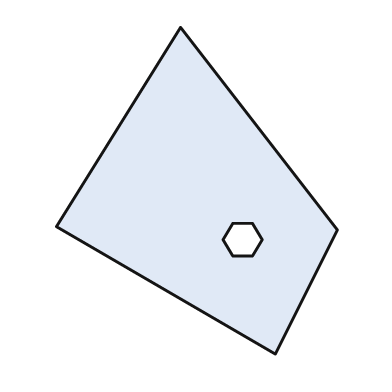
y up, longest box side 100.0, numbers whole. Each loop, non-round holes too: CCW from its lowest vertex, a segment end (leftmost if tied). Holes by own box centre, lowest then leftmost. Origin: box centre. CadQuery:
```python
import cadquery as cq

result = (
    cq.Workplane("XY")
    .moveTo(24.0, -50.0)
    .lineTo(43.0, -12.0)
    .lineTo(-5.0, 50.0)
    .lineTo(-43.0, -11.0)
    .close()
    .moveTo(11.0, -20.0)
    .lineTo(17.0, -20.0)
    .lineTo(20.0, -15.0)
    .lineTo(17.0, -10.0)
    .lineTo(11.0, -10.0)
    .lineTo(8.0, -15.0)
    .close()
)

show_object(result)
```